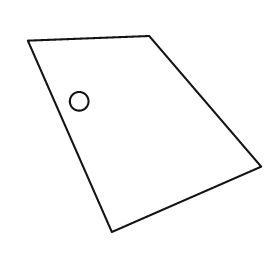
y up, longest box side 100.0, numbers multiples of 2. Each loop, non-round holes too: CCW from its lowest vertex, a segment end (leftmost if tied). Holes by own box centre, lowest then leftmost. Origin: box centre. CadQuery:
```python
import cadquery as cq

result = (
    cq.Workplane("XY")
    .moveTo(-14.0, -42.0)
    .lineTo(50.0, -14.0)
    .lineTo(2.0, 42.0)
    .lineTo(-50.0, 40.0)
    .close()
    .moveTo(-28.0, 14.0)
    .circle(4.0)
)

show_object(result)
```